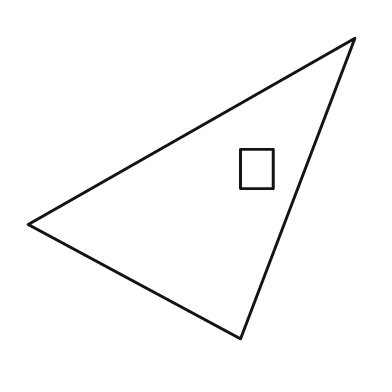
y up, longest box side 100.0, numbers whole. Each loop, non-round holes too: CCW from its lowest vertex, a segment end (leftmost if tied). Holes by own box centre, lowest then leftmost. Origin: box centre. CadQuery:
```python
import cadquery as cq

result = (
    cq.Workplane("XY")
    .moveTo(15.0, -46.0)
    .lineTo(50.0, 46.0)
    .lineTo(-50.0, -11.0)
    .close()
    .moveTo(15.0, 0.0)
    .lineTo(25.0, 0.0)
    .lineTo(25.0, 12.0)
    .lineTo(15.0, 12.0)
    .close()
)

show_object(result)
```